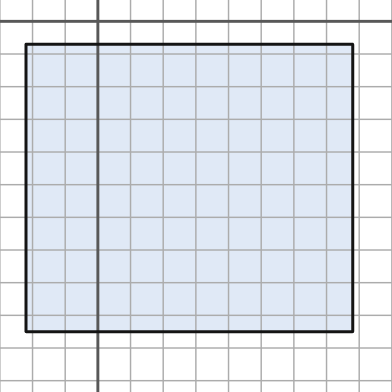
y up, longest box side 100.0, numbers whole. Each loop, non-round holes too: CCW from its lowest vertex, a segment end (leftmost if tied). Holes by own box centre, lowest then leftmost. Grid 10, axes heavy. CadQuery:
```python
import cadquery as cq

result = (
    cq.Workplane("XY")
    .moveTo(-22.0, -95.0)
    .lineTo(78.0, -95.0)
    .lineTo(78.0, -7.0)
    .lineTo(-22.0, -7.0)
    .close()
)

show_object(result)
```